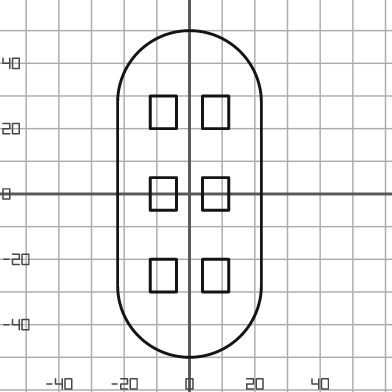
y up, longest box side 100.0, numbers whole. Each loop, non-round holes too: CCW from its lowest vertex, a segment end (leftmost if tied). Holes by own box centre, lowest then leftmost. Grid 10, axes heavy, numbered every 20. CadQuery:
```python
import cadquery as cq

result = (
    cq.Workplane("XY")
    .moveTo(-22.0, -28.0)
    .threePointArc((0.0, -50.0), (22.0, -28.0))
    .lineTo(22.0, 28.0)
    .threePointArc((0.0, 50.0), (-22.0, 28.0))
    .close()
    .moveTo(-12.0, -30.0)
    .lineTo(-4.0, -30.0)
    .lineTo(-4.0, -20.0)
    .lineTo(-12.0, -20.0)
    .close()
    .moveTo(4.0, -30.0)
    .lineTo(12.0, -30.0)
    .lineTo(12.0, -20.0)
    .lineTo(4.0, -20.0)
    .close()
    .moveTo(-12.0, -5.0)
    .lineTo(-4.0, -5.0)
    .lineTo(-4.0, 5.0)
    .lineTo(-12.0, 5.0)
    .close()
    .moveTo(4.0, -5.0)
    .lineTo(12.0, -5.0)
    .lineTo(12.0, 5.0)
    .lineTo(4.0, 5.0)
    .close()
    .moveTo(-12.0, 20.0)
    .lineTo(-4.0, 20.0)
    .lineTo(-4.0, 30.0)
    .lineTo(-12.0, 30.0)
    .close()
    .moveTo(4.0, 20.0)
    .lineTo(12.0, 20.0)
    .lineTo(12.0, 30.0)
    .lineTo(4.0, 30.0)
    .close()
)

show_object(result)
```